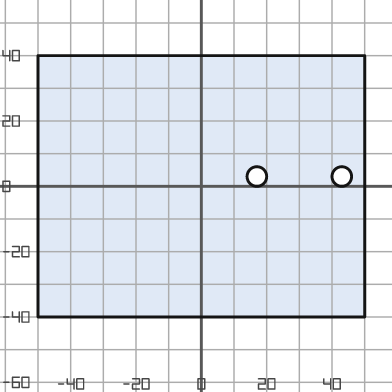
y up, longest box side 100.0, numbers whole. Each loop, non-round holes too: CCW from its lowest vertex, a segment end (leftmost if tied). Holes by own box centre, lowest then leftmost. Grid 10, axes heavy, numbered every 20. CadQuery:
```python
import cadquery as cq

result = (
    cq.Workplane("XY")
    .moveTo(-50.0, -40.0)
    .lineTo(50.0, -40.0)
    .lineTo(50.0, 40.0)
    .lineTo(-50.0, 40.0)
    .close()
    .moveTo(17.0, 3.0)
    .circle(3.0)
    .moveTo(43.0, 3.0)
    .circle(3.0)
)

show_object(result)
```